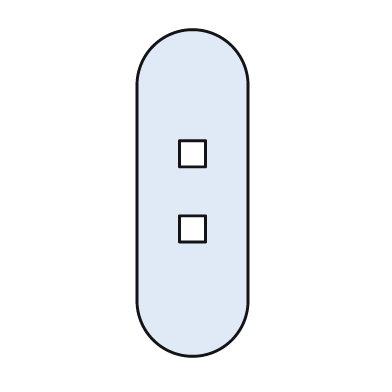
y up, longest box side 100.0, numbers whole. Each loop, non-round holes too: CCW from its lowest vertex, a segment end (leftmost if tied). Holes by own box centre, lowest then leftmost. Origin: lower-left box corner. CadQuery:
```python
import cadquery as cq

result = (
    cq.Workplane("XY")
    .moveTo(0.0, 17.0)
    .threePointArc((17.0, 0.0), (34.0, 17.0))
    .lineTo(34.0, 83.0)
    .threePointArc((17.0, 100.0), (0.0, 83.0))
    .close()
    .moveTo(13.0, 35.0)
    .lineTo(21.0, 35.0)
    .lineTo(21.0, 43.0)
    .lineTo(13.0, 43.0)
    .close()
    .moveTo(13.0, 58.0)
    .lineTo(21.0, 58.0)
    .lineTo(21.0, 66.0)
    .lineTo(13.0, 66.0)
    .close()
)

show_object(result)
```